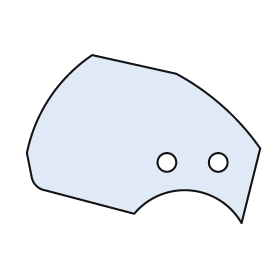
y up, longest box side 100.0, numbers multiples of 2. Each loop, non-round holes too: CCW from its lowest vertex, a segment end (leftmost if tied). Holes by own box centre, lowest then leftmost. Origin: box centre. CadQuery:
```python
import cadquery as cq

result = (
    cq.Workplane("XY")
    .moveTo(42.0, -36.0)
    .lineTo(50.0, -4.0)
    .threePointArc((34.0, 14.0), (14.0, 28.0))
    .lineTo(-22.0, 36.0)
    .threePointArc((-40.0, 18.0), (-50.0, -6.0))
    .lineTo(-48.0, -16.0)
    .threePointArc((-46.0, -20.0), (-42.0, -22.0))
    .lineTo(-4.0, -32.0)
    .threePointArc((20.0, -22.0), (42.0, -36.0))
    .close()
    .moveTo(10.0, -10.0)
    .circle(4.0)
    .moveTo(32.0, -10.0)
    .circle(4.0)
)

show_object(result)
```